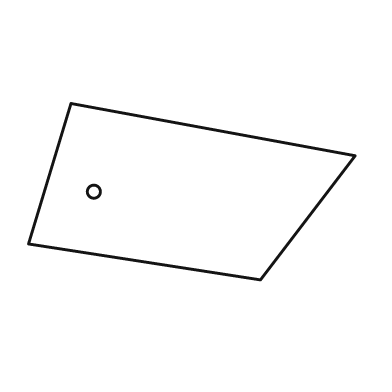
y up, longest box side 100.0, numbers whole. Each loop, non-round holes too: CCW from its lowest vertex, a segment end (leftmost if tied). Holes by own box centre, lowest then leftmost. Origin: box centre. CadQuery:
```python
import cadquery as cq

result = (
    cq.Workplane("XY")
    .moveTo(21.0, -27.0)
    .lineTo(50.0, 11.0)
    .lineTo(-37.0, 27.0)
    .lineTo(-50.0, -16.0)
    .close()
    .moveTo(-30.0, 0.0)
    .circle(2.0)
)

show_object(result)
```